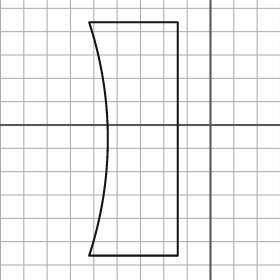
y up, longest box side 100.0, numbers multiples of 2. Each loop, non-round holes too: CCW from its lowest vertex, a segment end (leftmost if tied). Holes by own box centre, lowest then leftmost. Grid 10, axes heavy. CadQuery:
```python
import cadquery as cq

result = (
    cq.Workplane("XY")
    .moveTo(-52.0, -56.0)
    .lineTo(-14.0, -56.0)
    .lineTo(-14.0, 44.0)
    .lineTo(-52.0, 44.0)
    .threePointArc((-44.0, -6.0), (-52.0, -56.0))
    .close()
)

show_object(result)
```